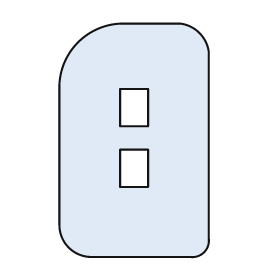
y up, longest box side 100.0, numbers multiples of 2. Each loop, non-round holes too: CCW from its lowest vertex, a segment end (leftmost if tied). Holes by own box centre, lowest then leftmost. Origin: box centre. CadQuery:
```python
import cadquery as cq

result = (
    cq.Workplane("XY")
    .moveTo(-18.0, -50.0)
    .lineTo(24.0, -50.0)
    .threePointArc((30.0, -48.0), (32.0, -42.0))
    .lineTo(32.0, 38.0)
    .threePointArc((28.0, 46.0), (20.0, 50.0))
    .lineTo(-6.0, 50.0)
    .threePointArc((-24.0, 42.0), (-32.0, 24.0))
    .lineTo(-32.0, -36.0)
    .threePointArc((-28.0, -46.0), (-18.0, -50.0))
    .close()
    .moveTo(-6.0, -20.0)
    .lineTo(6.0, -20.0)
    .lineTo(6.0, -4.0)
    .lineTo(-6.0, -4.0)
    .close()
    .moveTo(-6.0, 6.0)
    .lineTo(6.0, 6.0)
    .lineTo(6.0, 22.0)
    .lineTo(-6.0, 22.0)
    .close()
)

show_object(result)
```